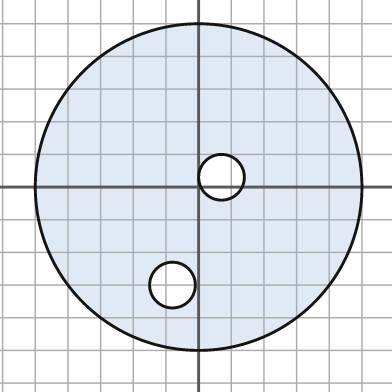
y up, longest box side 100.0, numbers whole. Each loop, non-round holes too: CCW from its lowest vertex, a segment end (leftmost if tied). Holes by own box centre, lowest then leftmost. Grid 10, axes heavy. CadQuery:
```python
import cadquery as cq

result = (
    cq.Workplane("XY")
    .moveTo(0.0, 0.0)
    .circle(50.0)
    .moveTo(-8.0, -30.0)
    .circle(7.0)
    .moveTo(7.0, 3.0)
    .circle(7.0)
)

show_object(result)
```